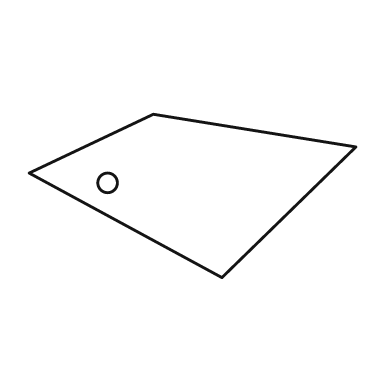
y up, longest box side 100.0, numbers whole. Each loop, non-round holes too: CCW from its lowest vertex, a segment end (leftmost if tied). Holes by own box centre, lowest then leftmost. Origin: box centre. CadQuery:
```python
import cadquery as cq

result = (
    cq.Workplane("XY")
    .moveTo(9.0, -25.0)
    .lineTo(50.0, 15.0)
    .lineTo(-12.0, 25.0)
    .lineTo(-50.0, 7.0)
    .close()
    .moveTo(-26.0, 4.0)
    .circle(3.0)
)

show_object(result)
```